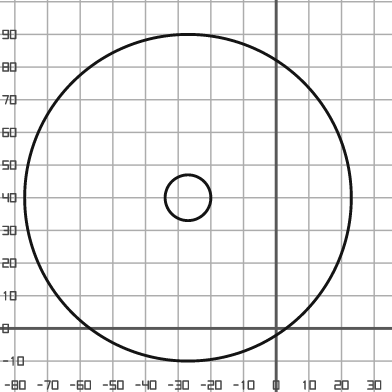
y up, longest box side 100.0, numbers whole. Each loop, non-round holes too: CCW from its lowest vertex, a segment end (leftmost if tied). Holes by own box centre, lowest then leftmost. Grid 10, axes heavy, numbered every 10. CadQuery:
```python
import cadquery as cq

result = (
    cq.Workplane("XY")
    .moveTo(-27.0, 40.0)
    .circle(50.0)
    .moveTo(-27.0, 40.0)
    .circle(7.0)
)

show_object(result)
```